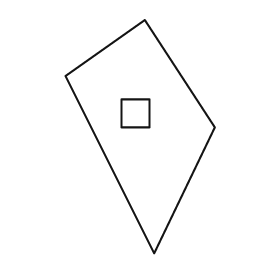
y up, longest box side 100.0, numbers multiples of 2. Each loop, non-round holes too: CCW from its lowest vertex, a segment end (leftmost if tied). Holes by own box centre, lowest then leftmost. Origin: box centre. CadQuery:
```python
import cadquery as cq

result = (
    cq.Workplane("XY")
    .moveTo(6.0, -50.0)
    .lineTo(32.0, 4.0)
    .lineTo(2.0, 50.0)
    .lineTo(-32.0, 26.0)
    .close()
    .moveTo(-8.0, 4.0)
    .lineTo(4.0, 4.0)
    .lineTo(4.0, 16.0)
    .lineTo(-8.0, 16.0)
    .close()
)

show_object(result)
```